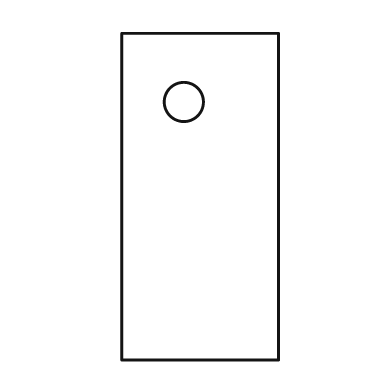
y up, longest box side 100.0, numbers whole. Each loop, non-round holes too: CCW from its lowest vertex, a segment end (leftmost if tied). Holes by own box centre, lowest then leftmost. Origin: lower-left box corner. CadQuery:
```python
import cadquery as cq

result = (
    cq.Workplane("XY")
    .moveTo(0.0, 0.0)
    .lineTo(48.0, 0.0)
    .lineTo(48.0, 100.0)
    .lineTo(0.0, 100.0)
    .close()
    .moveTo(19.0, 79.0)
    .circle(6.0)
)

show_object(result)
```